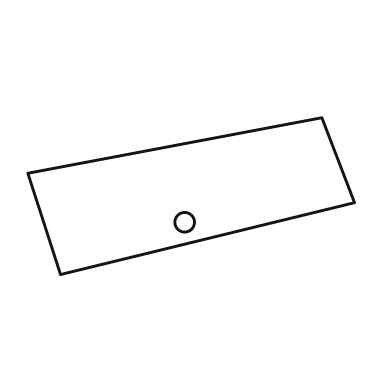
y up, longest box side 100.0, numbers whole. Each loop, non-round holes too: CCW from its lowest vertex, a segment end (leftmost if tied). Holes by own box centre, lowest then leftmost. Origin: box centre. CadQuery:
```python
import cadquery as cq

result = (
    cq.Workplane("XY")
    .moveTo(-40.0, -24.0)
    .lineTo(50.0, -2.0)
    .lineTo(40.0, 24.0)
    .lineTo(-50.0, 7.0)
    .close()
    .moveTo(-2.0, -8.0)
    .circle(3.0)
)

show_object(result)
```